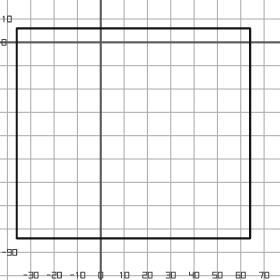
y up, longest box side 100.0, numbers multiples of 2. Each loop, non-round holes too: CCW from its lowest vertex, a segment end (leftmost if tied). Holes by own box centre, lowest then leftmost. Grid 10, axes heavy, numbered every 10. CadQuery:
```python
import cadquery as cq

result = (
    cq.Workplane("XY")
    .moveTo(-36.0, -84.0)
    .lineTo(64.0, -84.0)
    .lineTo(64.0, 6.0)
    .lineTo(-36.0, 6.0)
    .close()
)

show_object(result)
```